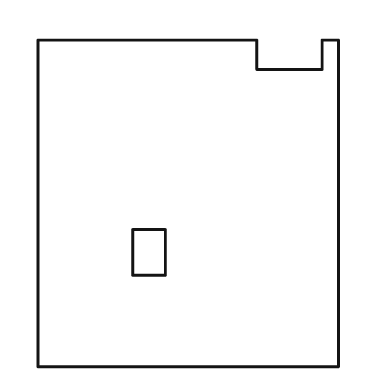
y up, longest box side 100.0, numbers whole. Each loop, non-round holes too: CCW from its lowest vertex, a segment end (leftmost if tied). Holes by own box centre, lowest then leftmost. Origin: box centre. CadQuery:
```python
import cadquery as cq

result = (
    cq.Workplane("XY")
    .moveTo(-46.0, -50.0)
    .lineTo(46.0, -50.0)
    .lineTo(46.0, 50.0)
    .lineTo(41.0, 50.0)
    .lineTo(41.0, 41.0)
    .lineTo(21.0, 41.0)
    .lineTo(21.0, 50.0)
    .lineTo(-46.0, 50.0)
    .close()
    .moveTo(-17.0, -22.0)
    .lineTo(-7.0, -22.0)
    .lineTo(-7.0, -8.0)
    .lineTo(-17.0, -8.0)
    .close()
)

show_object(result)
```